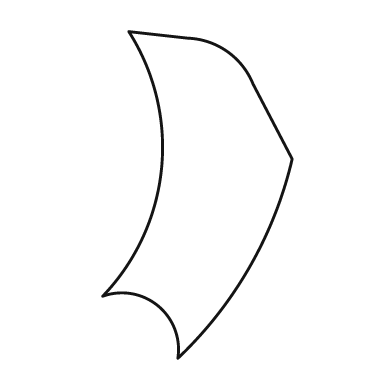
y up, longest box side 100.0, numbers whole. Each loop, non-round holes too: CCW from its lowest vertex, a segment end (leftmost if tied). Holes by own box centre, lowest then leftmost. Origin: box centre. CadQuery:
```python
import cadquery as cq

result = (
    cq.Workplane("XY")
    .moveTo(-6.0, -50.0)
    .threePointArc((16.0, -22.0), (29.0, 11.0))
    .lineTo(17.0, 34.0)
    .threePointArc((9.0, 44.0), (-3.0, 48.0))
    .lineTo(-21.0, 50.0)
    .threePointArc((-11.0, 8.0), (-29.0, -31.0))
    .threePointArc((-12.0, -34.0), (-6.0, -50.0))
    .close()
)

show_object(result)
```